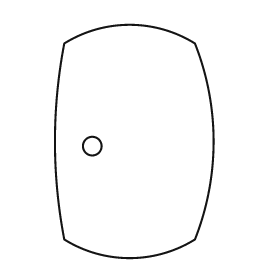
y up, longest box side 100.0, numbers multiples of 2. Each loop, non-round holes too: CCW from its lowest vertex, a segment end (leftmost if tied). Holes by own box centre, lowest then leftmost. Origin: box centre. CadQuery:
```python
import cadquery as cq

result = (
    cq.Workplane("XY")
    .moveTo(-30.0, -42.0)
    .threePointArc((-2.0, -50.0), (26.0, -42.0))
    .threePointArc((34.0, 0.0), (26.0, 42.0))
    .threePointArc((-2.0, 50.0), (-30.0, 42.0))
    .threePointArc((-34.0, 0.0), (-30.0, -42.0))
    .close()
    .moveTo(-18.0, -2.0)
    .circle(4.0)
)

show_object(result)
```